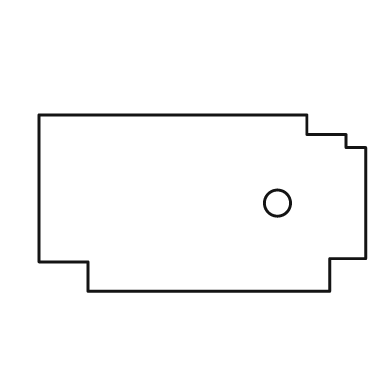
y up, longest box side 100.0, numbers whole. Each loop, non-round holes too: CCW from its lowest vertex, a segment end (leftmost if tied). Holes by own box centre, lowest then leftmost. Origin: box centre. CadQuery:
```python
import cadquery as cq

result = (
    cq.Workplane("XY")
    .moveTo(-35.0, -27.0)
    .lineTo(39.0, -27.0)
    .lineTo(39.0, -17.0)
    .lineTo(50.0, -17.0)
    .lineTo(50.0, 17.0)
    .lineTo(44.0, 17.0)
    .lineTo(44.0, 21.0)
    .lineTo(32.0, 21.0)
    .lineTo(32.0, 27.0)
    .lineTo(-50.0, 27.0)
    .lineTo(-50.0, -18.0)
    .lineTo(-35.0, -18.0)
    .close()
    .moveTo(23.0, 0.0)
    .circle(4.0)
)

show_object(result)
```